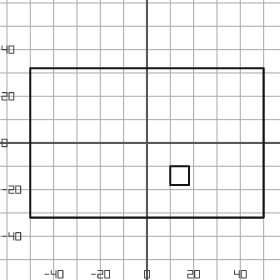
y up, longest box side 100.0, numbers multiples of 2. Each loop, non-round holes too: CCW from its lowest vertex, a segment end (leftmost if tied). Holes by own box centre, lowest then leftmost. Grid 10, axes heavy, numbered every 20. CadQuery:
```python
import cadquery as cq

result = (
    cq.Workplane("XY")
    .moveTo(-50.0, -32.0)
    .lineTo(50.0, -32.0)
    .lineTo(50.0, 32.0)
    .lineTo(-50.0, 32.0)
    .close()
    .moveTo(10.0, -18.0)
    .lineTo(18.0, -18.0)
    .lineTo(18.0, -10.0)
    .lineTo(10.0, -10.0)
    .close()
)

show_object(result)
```